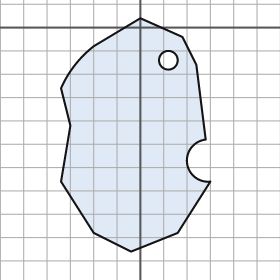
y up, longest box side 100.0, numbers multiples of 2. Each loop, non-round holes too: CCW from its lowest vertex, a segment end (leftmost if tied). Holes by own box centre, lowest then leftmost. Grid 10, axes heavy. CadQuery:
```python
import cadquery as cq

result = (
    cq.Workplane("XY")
    .moveTo(-4.0, -96.0)
    .lineTo(16.0, -88.0)
    .lineTo(30.0, -66.0)
    .threePointArc((20.0, -58.0), (28.0, -48.0))
    .lineTo(24.0, -16.0)
    .lineTo(18.0, -4.0)
    .lineTo(0.0, 4.0)
    .lineTo(-20.0, -8.0)
    .threePointArc((-28.0, -16.0), (-34.0, -26.0))
    .lineTo(-30.0, -42.0)
    .lineTo(-34.0, -66.0)
    .lineTo(-20.0, -88.0)
    .close()
    .moveTo(12.0, -14.0)
    .circle(4.0)
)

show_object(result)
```